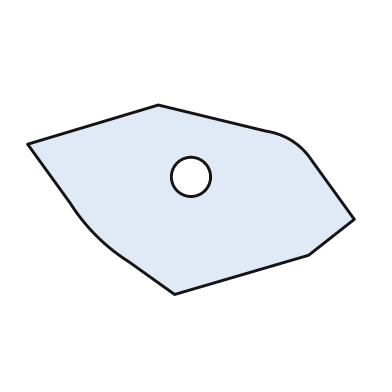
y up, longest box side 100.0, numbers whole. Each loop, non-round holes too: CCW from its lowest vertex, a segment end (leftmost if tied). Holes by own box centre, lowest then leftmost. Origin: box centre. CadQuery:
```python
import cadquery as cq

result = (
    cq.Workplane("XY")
    .moveTo(-5.0, -29.0)
    .lineTo(36.0, -17.0)
    .lineTo(50.0, -6.0)
    .lineTo(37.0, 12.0)
    .threePointArc((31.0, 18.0), (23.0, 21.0))
    .lineTo(-10.0, 29.0)
    .lineTo(-50.0, 17.0)
    .lineTo(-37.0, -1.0)
    .threePointArc((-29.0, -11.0), (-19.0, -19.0))
    .close()
    .moveTo(0.0, 7.0)
    .circle(6.0)
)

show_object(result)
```